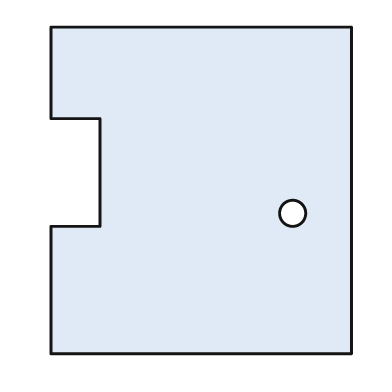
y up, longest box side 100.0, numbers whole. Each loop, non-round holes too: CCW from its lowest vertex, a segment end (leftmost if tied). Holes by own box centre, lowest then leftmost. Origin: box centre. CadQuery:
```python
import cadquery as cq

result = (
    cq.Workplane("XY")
    .moveTo(-46.0, -50.0)
    .lineTo(46.0, -50.0)
    .lineTo(46.0, 50.0)
    .lineTo(-46.0, 50.0)
    .lineTo(-46.0, 22.0)
    .lineTo(-31.0, 22.0)
    .lineTo(-31.0, -11.0)
    .lineTo(-46.0, -11.0)
    .close()
    .moveTo(28.0, -7.0)
    .circle(4.0)
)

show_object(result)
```